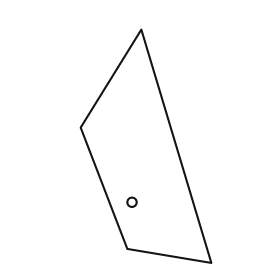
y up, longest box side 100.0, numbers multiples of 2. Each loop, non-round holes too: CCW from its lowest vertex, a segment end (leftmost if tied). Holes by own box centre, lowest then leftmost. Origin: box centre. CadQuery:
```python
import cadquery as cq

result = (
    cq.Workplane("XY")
    .moveTo(28.0, -50.0)
    .lineTo(-2.0, 50.0)
    .lineTo(-28.0, 8.0)
    .lineTo(-8.0, -44.0)
    .close()
    .moveTo(-6.0, -24.0)
    .circle(2.0)
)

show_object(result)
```